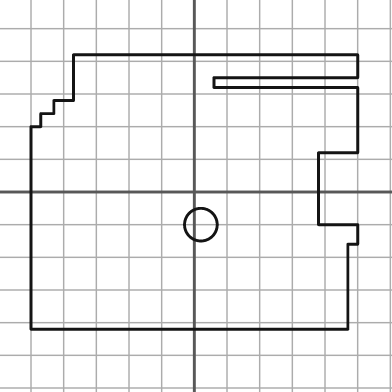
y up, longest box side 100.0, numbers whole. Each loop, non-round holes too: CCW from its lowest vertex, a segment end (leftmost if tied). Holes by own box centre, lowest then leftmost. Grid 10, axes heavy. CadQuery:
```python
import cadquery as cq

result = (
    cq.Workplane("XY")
    .moveTo(-50.0, -42.0)
    .lineTo(47.0, -42.0)
    .lineTo(47.0, -16.0)
    .lineTo(50.0, -16.0)
    .lineTo(50.0, -10.0)
    .lineTo(38.0, -10.0)
    .lineTo(38.0, 12.0)
    .lineTo(50.0, 12.0)
    .lineTo(50.0, 32.0)
    .lineTo(6.0, 32.0)
    .lineTo(6.0, 35.0)
    .lineTo(50.0, 35.0)
    .lineTo(50.0, 42.0)
    .lineTo(-37.0, 42.0)
    .lineTo(-37.0, 28.0)
    .lineTo(-43.0, 28.0)
    .lineTo(-43.0, 24.0)
    .lineTo(-47.0, 24.0)
    .lineTo(-47.0, 20.0)
    .lineTo(-50.0, 20.0)
    .close()
    .moveTo(2.0, -10.0)
    .circle(5.0)
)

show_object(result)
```